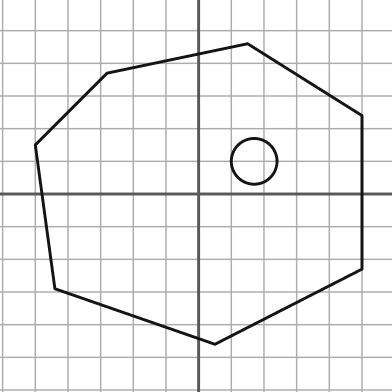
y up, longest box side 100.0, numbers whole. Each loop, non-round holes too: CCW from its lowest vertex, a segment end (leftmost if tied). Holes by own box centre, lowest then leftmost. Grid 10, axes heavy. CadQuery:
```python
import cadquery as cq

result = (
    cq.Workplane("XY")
    .moveTo(5.0, -46.0)
    .lineTo(50.0, -23.0)
    .lineTo(50.0, 24.0)
    .lineTo(15.0, 46.0)
    .lineTo(-28.0, 37.0)
    .lineTo(-50.0, 15.0)
    .lineTo(-44.0, -29.0)
    .close()
    .moveTo(17.0, 10.0)
    .circle(7.0)
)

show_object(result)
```